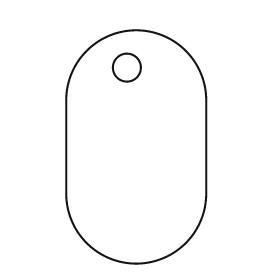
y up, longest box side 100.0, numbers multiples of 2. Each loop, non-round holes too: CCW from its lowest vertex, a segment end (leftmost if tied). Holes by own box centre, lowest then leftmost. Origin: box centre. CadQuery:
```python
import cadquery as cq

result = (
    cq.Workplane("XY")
    .moveTo(-30.0, -20.0)
    .threePointArc((0.0, -50.0), (30.0, -20.0))
    .lineTo(30.0, 20.0)
    .threePointArc((0.0, 50.0), (-30.0, 20.0))
    .close()
    .moveTo(-4.0, 34.0)
    .circle(6.0)
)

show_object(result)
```